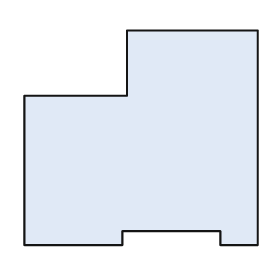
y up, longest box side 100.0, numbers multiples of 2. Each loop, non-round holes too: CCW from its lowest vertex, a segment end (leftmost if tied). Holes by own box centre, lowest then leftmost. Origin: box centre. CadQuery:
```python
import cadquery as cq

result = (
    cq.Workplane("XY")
    .moveTo(-50.0, -46.0)
    .lineTo(-8.0, -46.0)
    .lineTo(-8.0, -40.0)
    .lineTo(34.0, -40.0)
    .lineTo(34.0, -46.0)
    .lineTo(50.0, -46.0)
    .lineTo(50.0, 46.0)
    .lineTo(-6.0, 46.0)
    .lineTo(-6.0, 18.0)
    .lineTo(-50.0, 18.0)
    .close()
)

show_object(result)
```